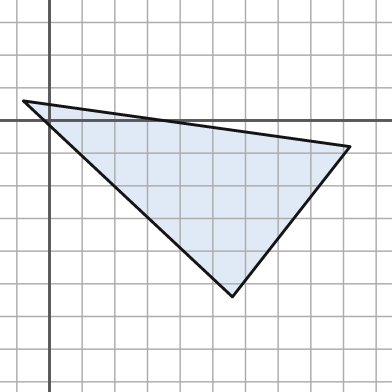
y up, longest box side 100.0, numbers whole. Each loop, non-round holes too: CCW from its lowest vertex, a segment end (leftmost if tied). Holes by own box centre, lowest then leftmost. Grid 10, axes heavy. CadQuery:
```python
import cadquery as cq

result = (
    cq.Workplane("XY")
    .moveTo(56.0, -54.0)
    .lineTo(92.0, -8.0)
    .lineTo(-8.0, 6.0)
    .close()
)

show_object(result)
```